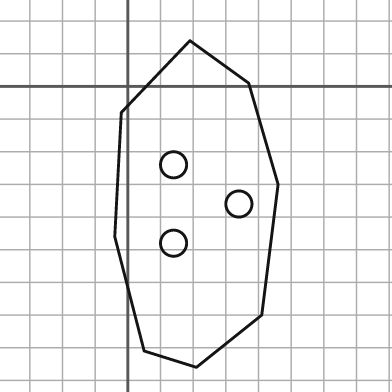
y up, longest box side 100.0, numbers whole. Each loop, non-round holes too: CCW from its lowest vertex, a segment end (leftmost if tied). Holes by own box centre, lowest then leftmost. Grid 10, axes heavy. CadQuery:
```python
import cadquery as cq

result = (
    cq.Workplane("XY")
    .moveTo(21.0, -86.0)
    .lineTo(41.0, -70.0)
    .lineTo(46.0, -30.0)
    .lineTo(37.0, 1.0)
    .lineTo(19.0, 14.0)
    .lineTo(-2.0, -8.0)
    .lineTo(-4.0, -46.0)
    .lineTo(5.0, -81.0)
    .close()
    .moveTo(14.0, -48.0)
    .circle(4.0)
    .moveTo(34.0, -36.0)
    .circle(4.0)
    .moveTo(14.0, -24.0)
    .circle(4.0)
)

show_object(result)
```